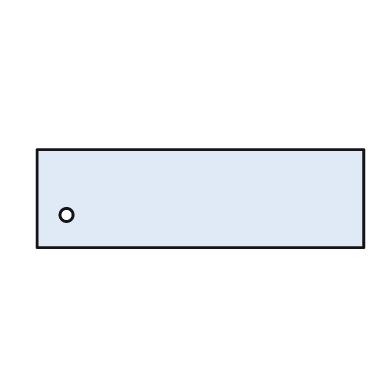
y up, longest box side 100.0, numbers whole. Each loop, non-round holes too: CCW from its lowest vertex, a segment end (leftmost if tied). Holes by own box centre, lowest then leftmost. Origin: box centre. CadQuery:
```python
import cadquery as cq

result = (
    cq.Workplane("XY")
    .moveTo(-50.0, -15.0)
    .lineTo(50.0, -15.0)
    .lineTo(50.0, 15.0)
    .lineTo(-50.0, 15.0)
    .close()
    .moveTo(-41.0, -5.0)
    .circle(2.0)
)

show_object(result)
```